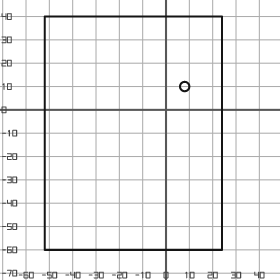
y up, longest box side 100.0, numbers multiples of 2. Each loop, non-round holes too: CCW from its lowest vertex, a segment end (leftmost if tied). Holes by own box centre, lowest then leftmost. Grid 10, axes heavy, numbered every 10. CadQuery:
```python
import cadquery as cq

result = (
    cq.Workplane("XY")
    .moveTo(-52.0, -60.0)
    .lineTo(24.0, -60.0)
    .lineTo(24.0, 40.0)
    .lineTo(-52.0, 40.0)
    .close()
    .moveTo(8.0, 10.0)
    .circle(2.0)
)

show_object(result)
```